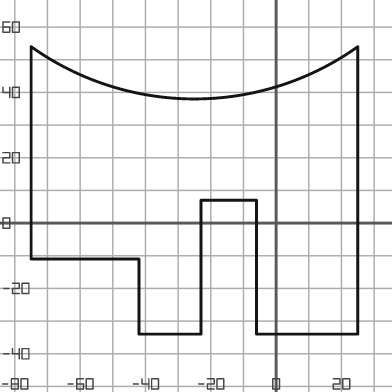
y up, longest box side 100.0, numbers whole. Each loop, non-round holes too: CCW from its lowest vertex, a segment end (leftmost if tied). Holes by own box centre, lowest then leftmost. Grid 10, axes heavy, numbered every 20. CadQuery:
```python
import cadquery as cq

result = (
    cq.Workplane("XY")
    .moveTo(-42.0, -34.0)
    .lineTo(-23.0, -34.0)
    .lineTo(-23.0, 7.0)
    .lineTo(-6.0, 7.0)
    .lineTo(-6.0, -34.0)
    .lineTo(25.0, -34.0)
    .lineTo(25.0, 54.0)
    .threePointArc((-25.0, 38.0), (-75.0, 54.0))
    .lineTo(-75.0, -11.0)
    .lineTo(-42.0, -11.0)
    .close()
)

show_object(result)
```